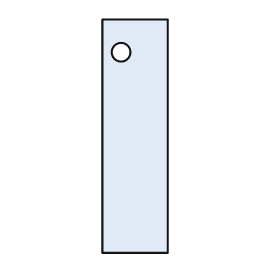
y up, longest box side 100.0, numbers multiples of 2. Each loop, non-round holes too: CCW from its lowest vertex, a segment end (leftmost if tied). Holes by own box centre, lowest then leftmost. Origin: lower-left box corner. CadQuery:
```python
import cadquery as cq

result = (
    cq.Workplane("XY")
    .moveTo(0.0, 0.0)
    .lineTo(28.0, 0.0)
    .lineTo(28.0, 100.0)
    .lineTo(0.0, 100.0)
    .close()
    .moveTo(8.0, 86.0)
    .circle(4.0)
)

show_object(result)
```